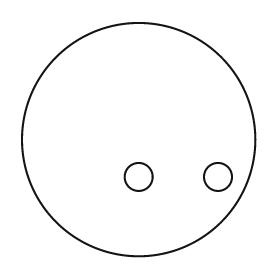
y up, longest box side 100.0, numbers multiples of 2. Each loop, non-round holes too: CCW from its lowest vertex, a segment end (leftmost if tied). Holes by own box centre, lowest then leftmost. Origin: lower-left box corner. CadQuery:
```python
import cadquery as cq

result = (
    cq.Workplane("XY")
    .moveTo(50.0, 50.0)
    .circle(50.0)
    .moveTo(50.0, 34.0)
    .circle(6.0)
    .moveTo(84.0, 34.0)
    .circle(6.0)
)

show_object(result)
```